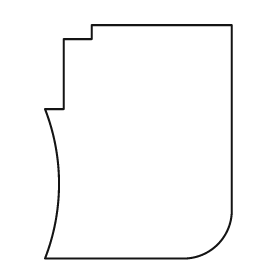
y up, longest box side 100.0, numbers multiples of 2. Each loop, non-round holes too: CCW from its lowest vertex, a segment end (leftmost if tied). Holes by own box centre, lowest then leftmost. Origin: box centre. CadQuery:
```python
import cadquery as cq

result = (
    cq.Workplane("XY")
    .moveTo(-40.0, -50.0)
    .lineTo(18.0, -50.0)
    .threePointArc((34.0, -44.0), (40.0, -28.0))
    .lineTo(40.0, 50.0)
    .lineTo(-20.0, 50.0)
    .lineTo(-20.0, 44.0)
    .lineTo(-32.0, 44.0)
    .lineTo(-32.0, 14.0)
    .lineTo(-40.0, 14.0)
    .threePointArc((-34.0, -18.0), (-40.0, -50.0))
    .close()
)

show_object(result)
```